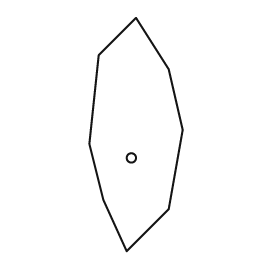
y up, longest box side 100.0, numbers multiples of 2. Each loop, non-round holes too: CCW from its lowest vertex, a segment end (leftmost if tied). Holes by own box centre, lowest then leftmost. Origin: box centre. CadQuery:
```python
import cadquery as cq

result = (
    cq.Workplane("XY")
    .moveTo(-4.0, -50.0)
    .lineTo(14.0, -32.0)
    .lineTo(20.0, 2.0)
    .lineTo(14.0, 28.0)
    .lineTo(0.0, 50.0)
    .lineTo(-16.0, 34.0)
    .lineTo(-20.0, -4.0)
    .lineTo(-14.0, -28.0)
    .close()
    .moveTo(-2.0, -10.0)
    .circle(2.0)
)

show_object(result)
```